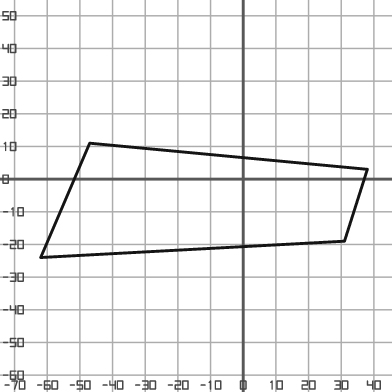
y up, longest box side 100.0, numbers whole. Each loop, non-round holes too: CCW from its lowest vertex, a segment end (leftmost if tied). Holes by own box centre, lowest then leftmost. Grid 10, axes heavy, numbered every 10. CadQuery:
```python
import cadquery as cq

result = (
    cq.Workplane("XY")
    .moveTo(-62.0, -24.0)
    .lineTo(31.0, -19.0)
    .lineTo(38.0, 3.0)
    .lineTo(-47.0, 11.0)
    .close()
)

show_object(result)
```